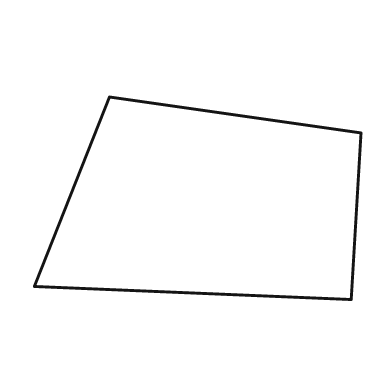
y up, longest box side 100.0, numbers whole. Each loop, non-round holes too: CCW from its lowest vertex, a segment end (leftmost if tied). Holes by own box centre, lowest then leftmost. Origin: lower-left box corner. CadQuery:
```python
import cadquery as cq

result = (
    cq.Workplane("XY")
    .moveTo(97.0, 0.0)
    .lineTo(100.0, 51.0)
    .lineTo(23.0, 62.0)
    .lineTo(0.0, 4.0)
    .close()
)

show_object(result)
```